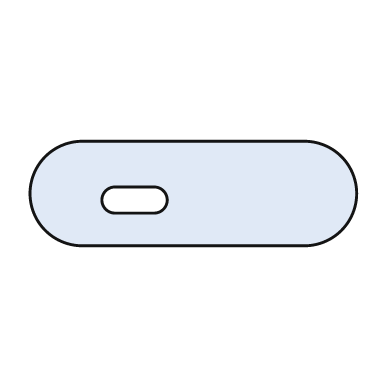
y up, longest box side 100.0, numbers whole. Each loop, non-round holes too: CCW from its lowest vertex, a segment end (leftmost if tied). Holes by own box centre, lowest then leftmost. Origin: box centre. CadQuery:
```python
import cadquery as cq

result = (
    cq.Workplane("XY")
    .moveTo(-34.0, -16.0)
    .lineTo(34.0, -16.0)
    .threePointArc((50.0, 0.0), (34.0, 16.0))
    .lineTo(-34.0, 16.0)
    .threePointArc((-50.0, 0.0), (-34.0, -16.0))
    .close()
    .moveTo(-24.0, -6.0)
    .lineTo(-12.0, -6.0)
    .threePointArc((-8.0, -2.0), (-12.0, 2.0))
    .lineTo(-24.0, 2.0)
    .threePointArc((-28.0, -2.0), (-24.0, -6.0))
    .close()
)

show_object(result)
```